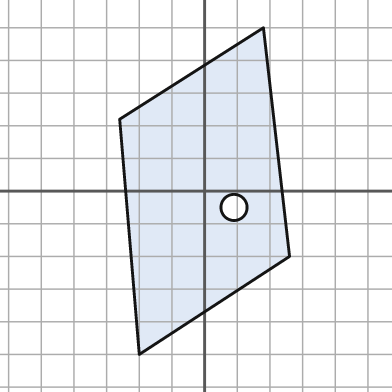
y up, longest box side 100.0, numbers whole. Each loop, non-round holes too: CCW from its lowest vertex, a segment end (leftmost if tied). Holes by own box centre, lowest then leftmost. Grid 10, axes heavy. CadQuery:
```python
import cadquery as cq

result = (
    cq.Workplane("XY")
    .moveTo(-20.0, -50.0)
    .lineTo(26.0, -20.0)
    .lineTo(18.0, 50.0)
    .lineTo(-26.0, 22.0)
    .close()
    .moveTo(9.0, -5.0)
    .circle(4.0)
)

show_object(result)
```